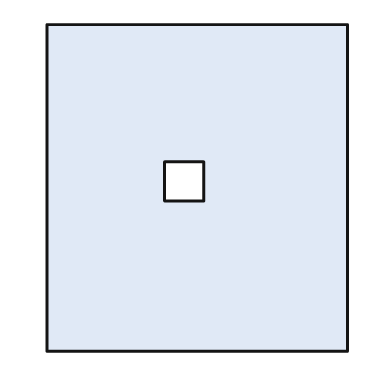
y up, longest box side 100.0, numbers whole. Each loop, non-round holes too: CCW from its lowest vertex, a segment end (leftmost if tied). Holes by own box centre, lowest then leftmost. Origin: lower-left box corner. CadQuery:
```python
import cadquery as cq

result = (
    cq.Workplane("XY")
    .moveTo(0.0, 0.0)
    .lineTo(92.0, 0.0)
    .lineTo(92.0, 100.0)
    .lineTo(0.0, 100.0)
    .close()
    .moveTo(36.0, 46.0)
    .lineTo(48.0, 46.0)
    .lineTo(48.0, 58.0)
    .lineTo(36.0, 58.0)
    .close()
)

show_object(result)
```